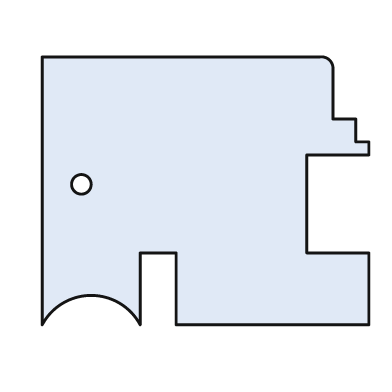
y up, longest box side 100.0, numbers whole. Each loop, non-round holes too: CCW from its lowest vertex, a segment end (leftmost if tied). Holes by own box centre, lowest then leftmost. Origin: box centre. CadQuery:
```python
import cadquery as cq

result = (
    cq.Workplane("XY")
    .moveTo(-50.0, -41.0)
    .threePointArc((-35.0, -32.0), (-20.0, -41.0))
    .lineTo(-20.0, -19.0)
    .lineTo(-9.0, -19.0)
    .lineTo(-9.0, -41.0)
    .lineTo(50.0, -41.0)
    .lineTo(50.0, -19.0)
    .lineTo(31.0, -19.0)
    .lineTo(31.0, 11.0)
    .lineTo(50.0, 11.0)
    .lineTo(50.0, 15.0)
    .lineTo(46.0, 15.0)
    .lineTo(46.0, 22.0)
    .lineTo(39.0, 22.0)
    .lineTo(39.0, 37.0)
    .threePointArc((38.0, 40.0), (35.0, 41.0))
    .lineTo(-50.0, 41.0)
    .close()
    .moveTo(-38.0, 2.0)
    .circle(3.0)
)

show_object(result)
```